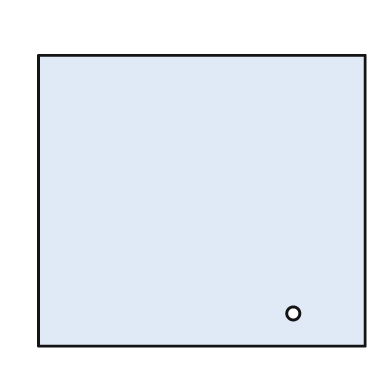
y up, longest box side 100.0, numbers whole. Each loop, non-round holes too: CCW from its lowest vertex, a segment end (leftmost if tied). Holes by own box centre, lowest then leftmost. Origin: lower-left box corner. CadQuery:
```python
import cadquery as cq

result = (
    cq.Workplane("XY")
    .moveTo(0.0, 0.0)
    .lineTo(100.0, 0.0)
    .lineTo(100.0, 89.0)
    .lineTo(0.0, 89.0)
    .close()
    .moveTo(78.0, 10.0)
    .circle(2.0)
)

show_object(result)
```